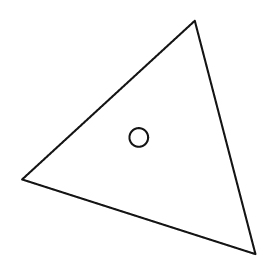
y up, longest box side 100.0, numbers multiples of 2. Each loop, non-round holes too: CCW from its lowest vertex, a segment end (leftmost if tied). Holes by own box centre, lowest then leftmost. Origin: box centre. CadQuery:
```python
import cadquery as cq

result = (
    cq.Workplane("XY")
    .moveTo(50.0, -50.0)
    .lineTo(24.0, 50.0)
    .lineTo(-50.0, -18.0)
    .close()
    .moveTo(0.0, 0.0)
    .circle(4.0)
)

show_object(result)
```